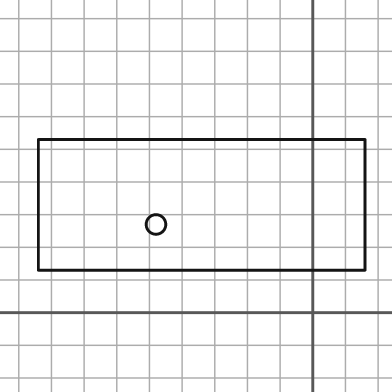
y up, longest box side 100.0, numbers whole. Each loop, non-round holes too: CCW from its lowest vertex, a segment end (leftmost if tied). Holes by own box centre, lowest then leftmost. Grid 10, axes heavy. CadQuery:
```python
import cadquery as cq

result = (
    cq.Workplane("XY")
    .moveTo(-84.0, 13.0)
    .lineTo(16.0, 13.0)
    .lineTo(16.0, 53.0)
    .lineTo(-84.0, 53.0)
    .close()
    .moveTo(-48.0, 27.0)
    .circle(3.0)
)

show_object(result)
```